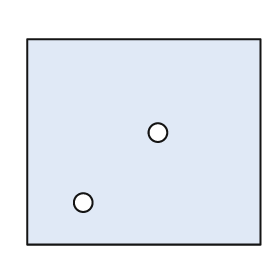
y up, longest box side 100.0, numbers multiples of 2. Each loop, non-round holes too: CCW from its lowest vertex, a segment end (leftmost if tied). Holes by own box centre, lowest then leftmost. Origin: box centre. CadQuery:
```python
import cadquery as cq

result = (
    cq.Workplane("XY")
    .moveTo(-50.0, -44.0)
    .lineTo(50.0, -44.0)
    .lineTo(50.0, 44.0)
    .lineTo(-50.0, 44.0)
    .close()
    .moveTo(-26.0, -26.0)
    .circle(4.0)
    .moveTo(6.0, 4.0)
    .circle(4.0)
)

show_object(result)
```